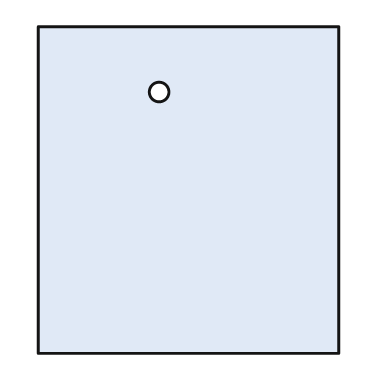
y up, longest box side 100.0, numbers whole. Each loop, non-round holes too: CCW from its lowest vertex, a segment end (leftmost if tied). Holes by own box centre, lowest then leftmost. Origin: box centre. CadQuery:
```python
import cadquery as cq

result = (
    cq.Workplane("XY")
    .moveTo(-46.0, -50.0)
    .lineTo(46.0, -50.0)
    .lineTo(46.0, 50.0)
    .lineTo(-46.0, 50.0)
    .close()
    .moveTo(-9.0, 30.0)
    .circle(3.0)
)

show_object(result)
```